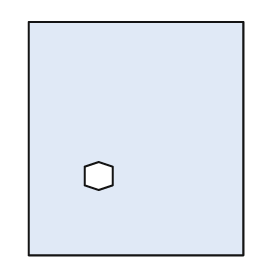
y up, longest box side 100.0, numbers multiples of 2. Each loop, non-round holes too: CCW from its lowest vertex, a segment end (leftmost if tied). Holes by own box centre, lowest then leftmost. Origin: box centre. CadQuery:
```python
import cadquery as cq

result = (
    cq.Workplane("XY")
    .moveTo(-46.0, -50.0)
    .lineTo(46.0, -50.0)
    .lineTo(46.0, 50.0)
    .lineTo(-46.0, 50.0)
    .close()
    .moveTo(-16.0, -22.0)
    .lineTo(-10.0, -20.0)
    .lineTo(-10.0, -12.0)
    .lineTo(-16.0, -10.0)
    .lineTo(-22.0, -12.0)
    .lineTo(-22.0, -20.0)
    .close()
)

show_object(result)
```